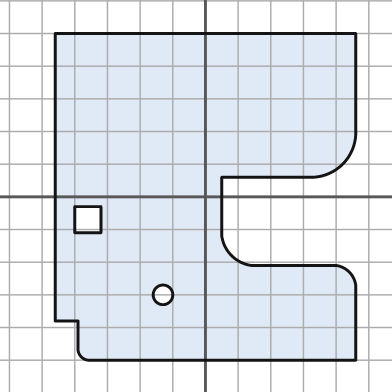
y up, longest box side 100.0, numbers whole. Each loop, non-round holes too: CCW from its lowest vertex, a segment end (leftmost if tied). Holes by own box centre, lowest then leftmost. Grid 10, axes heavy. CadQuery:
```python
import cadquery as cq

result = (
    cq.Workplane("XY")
    .moveTo(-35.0, -50.0)
    .lineTo(46.0, -50.0)
    .lineTo(46.0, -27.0)
    .threePointArc((44.0, -23.0), (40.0, -21.0))
    .lineTo(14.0, -21.0)
    .threePointArc((8.0, -18.0), (5.0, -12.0))
    .lineTo(5.0, 6.0)
    .lineTo(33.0, 6.0)
    .threePointArc((42.0, 10.0), (46.0, 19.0))
    .lineTo(46.0, 50.0)
    .lineTo(-46.0, 50.0)
    .lineTo(-46.0, -38.0)
    .lineTo(-39.0, -38.0)
    .lineTo(-39.0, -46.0)
    .threePointArc((-38.0, -49.0), (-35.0, -50.0))
    .close()
    .moveTo(-13.0, -30.0)
    .circle(3.0)
    .moveTo(-40.0, -11.0)
    .lineTo(-32.0, -11.0)
    .lineTo(-32.0, -3.0)
    .lineTo(-40.0, -3.0)
    .close()
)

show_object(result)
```